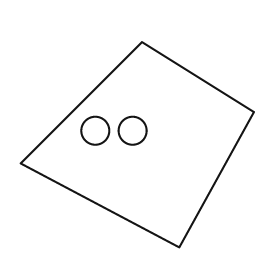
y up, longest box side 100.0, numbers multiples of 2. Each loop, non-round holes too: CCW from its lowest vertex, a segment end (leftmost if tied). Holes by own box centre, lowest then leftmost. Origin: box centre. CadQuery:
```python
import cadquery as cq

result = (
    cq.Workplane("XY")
    .moveTo(18.0, -44.0)
    .lineTo(50.0, 14.0)
    .lineTo(2.0, 44.0)
    .lineTo(-50.0, -8.0)
    .close()
    .moveTo(-18.0, 6.0)
    .circle(6.0)
    .moveTo(-2.0, 6.0)
    .circle(6.0)
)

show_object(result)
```